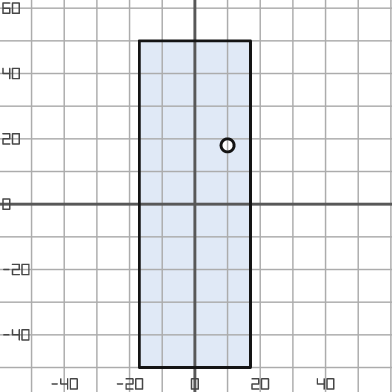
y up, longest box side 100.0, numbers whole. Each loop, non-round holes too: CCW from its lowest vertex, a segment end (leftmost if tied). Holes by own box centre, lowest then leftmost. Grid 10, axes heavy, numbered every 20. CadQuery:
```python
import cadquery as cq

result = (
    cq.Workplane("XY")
    .moveTo(-17.0, -50.0)
    .lineTo(17.0, -50.0)
    .lineTo(17.0, 50.0)
    .lineTo(-17.0, 50.0)
    .close()
    .moveTo(10.0, 18.0)
    .circle(2.0)
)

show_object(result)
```